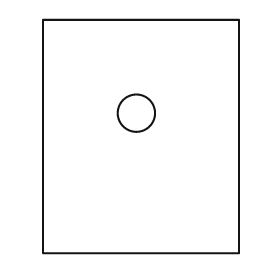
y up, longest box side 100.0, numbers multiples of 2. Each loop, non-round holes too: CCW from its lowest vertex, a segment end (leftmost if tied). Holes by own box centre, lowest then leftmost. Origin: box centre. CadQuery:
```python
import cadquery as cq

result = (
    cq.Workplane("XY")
    .moveTo(-42.0, -50.0)
    .lineTo(42.0, -50.0)
    .lineTo(42.0, 50.0)
    .lineTo(-42.0, 50.0)
    .close()
    .moveTo(-2.0, 10.0)
    .circle(8.0)
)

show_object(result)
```